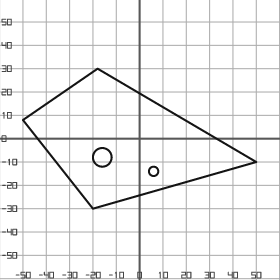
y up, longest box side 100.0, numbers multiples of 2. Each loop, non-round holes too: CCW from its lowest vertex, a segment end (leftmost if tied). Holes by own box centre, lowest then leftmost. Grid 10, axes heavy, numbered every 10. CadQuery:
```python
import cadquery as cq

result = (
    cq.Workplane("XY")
    .moveTo(-20.0, -30.0)
    .lineTo(50.0, -10.0)
    .lineTo(-18.0, 30.0)
    .lineTo(-50.0, 8.0)
    .close()
    .moveTo(6.0, -14.0)
    .circle(2.0)
    .moveTo(-16.0, -8.0)
    .circle(4.0)
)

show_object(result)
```